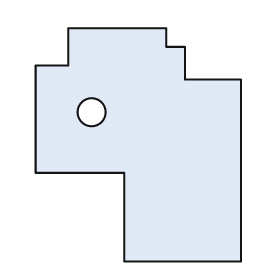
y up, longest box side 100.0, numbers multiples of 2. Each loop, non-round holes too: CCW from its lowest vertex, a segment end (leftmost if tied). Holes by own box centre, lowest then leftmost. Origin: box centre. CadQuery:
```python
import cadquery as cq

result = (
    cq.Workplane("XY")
    .moveTo(-6.0, -50.0)
    .lineTo(44.0, -50.0)
    .lineTo(44.0, 28.0)
    .lineTo(20.0, 28.0)
    .lineTo(20.0, 42.0)
    .lineTo(12.0, 42.0)
    .lineTo(12.0, 50.0)
    .lineTo(-30.0, 50.0)
    .lineTo(-30.0, 34.0)
    .lineTo(-44.0, 34.0)
    .lineTo(-44.0, -12.0)
    .lineTo(-6.0, -12.0)
    .close()
    .moveTo(-20.0, 14.0)
    .circle(6.0)
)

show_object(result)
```